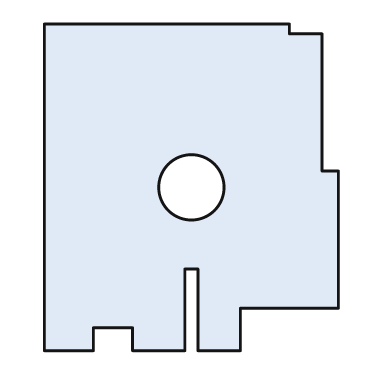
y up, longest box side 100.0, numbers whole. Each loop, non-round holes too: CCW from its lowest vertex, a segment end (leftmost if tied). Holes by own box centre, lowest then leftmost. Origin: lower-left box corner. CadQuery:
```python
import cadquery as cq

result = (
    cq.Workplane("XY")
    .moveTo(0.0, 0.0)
    .lineTo(15.0, 0.0)
    .lineTo(15.0, 7.0)
    .lineTo(27.0, 7.0)
    .lineTo(27.0, 0.0)
    .lineTo(43.0, 0.0)
    .lineTo(43.0, 25.0)
    .lineTo(47.0, 25.0)
    .lineTo(47.0, 0.0)
    .lineTo(60.0, 0.0)
    .lineTo(60.0, 13.0)
    .lineTo(90.0, 13.0)
    .lineTo(90.0, 55.0)
    .lineTo(85.0, 55.0)
    .lineTo(85.0, 97.0)
    .lineTo(75.0, 97.0)
    .lineTo(75.0, 100.0)
    .lineTo(0.0, 100.0)
    .close()
    .moveTo(45.0, 50.0)
    .circle(10.0)
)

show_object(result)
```